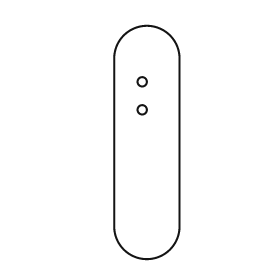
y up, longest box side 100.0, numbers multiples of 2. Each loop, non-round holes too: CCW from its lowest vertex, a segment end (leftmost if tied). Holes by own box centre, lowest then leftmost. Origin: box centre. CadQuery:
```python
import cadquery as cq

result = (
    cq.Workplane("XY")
    .moveTo(-14.0, -36.0)
    .threePointArc((0.0, -50.0), (14.0, -36.0))
    .lineTo(14.0, 36.0)
    .threePointArc((0.0, 50.0), (-14.0, 36.0))
    .close()
    .moveTo(-2.0, 14.0)
    .circle(2.0)
    .moveTo(-2.0, 26.0)
    .circle(2.0)
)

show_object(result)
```